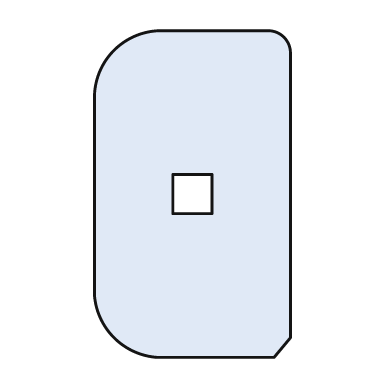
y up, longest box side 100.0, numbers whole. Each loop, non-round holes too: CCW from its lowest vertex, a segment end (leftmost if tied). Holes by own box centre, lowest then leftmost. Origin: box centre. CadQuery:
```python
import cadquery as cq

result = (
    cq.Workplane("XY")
    .moveTo(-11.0, -50.0)
    .lineTo(25.0, -50.0)
    .lineTo(30.0, -44.0)
    .lineTo(30.0, 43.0)
    .threePointArc((28.0, 48.0), (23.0, 50.0))
    .lineTo(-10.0, 50.0)
    .threePointArc((-24.0, 44.0), (-30.0, 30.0))
    .lineTo(-30.0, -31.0)
    .threePointArc((-24.0, -44.0), (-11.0, -50.0))
    .close()
    .moveTo(-6.0, -6.0)
    .lineTo(6.0, -6.0)
    .lineTo(6.0, 6.0)
    .lineTo(-6.0, 6.0)
    .close()
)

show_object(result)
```